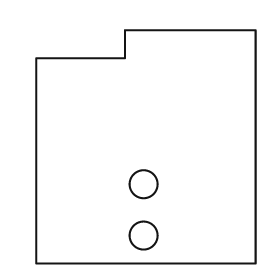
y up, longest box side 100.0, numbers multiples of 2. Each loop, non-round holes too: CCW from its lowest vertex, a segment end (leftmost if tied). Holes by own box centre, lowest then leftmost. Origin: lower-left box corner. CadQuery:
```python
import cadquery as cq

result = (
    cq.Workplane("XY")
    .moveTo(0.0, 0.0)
    .lineTo(94.0, 0.0)
    .lineTo(94.0, 100.0)
    .lineTo(38.0, 100.0)
    .lineTo(38.0, 88.0)
    .lineTo(0.0, 88.0)
    .close()
    .moveTo(46.0, 12.0)
    .circle(6.0)
    .moveTo(46.0, 34.0)
    .circle(6.0)
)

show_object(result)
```